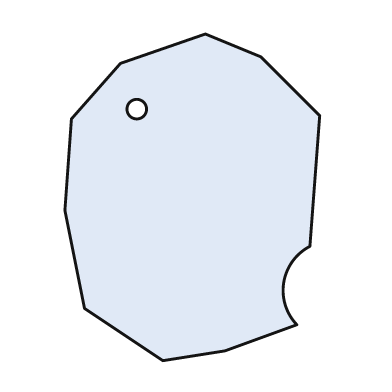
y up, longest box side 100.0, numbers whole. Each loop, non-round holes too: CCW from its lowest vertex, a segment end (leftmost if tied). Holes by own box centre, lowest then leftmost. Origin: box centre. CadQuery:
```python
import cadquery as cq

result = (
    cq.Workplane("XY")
    .moveTo(-9.0, -50.0)
    .lineTo(10.0, -47.0)
    .lineTo(32.0, -39.0)
    .threePointArc((28.0, -26.0), (36.0, -15.0))
    .lineTo(39.0, 25.0)
    .lineTo(21.0, 43.0)
    .lineTo(4.0, 50.0)
    .lineTo(-22.0, 41.0)
    .lineTo(-37.0, 24.0)
    .lineTo(-39.0, -4.0)
    .lineTo(-33.0, -34.0)
    .close()
    .moveTo(-17.0, 27.0)
    .circle(3.0)
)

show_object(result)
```